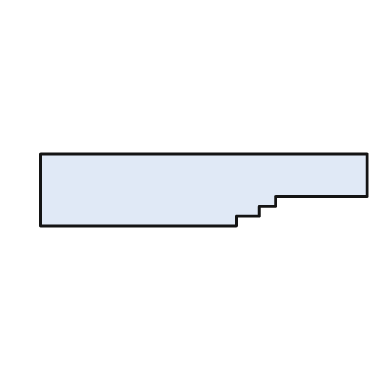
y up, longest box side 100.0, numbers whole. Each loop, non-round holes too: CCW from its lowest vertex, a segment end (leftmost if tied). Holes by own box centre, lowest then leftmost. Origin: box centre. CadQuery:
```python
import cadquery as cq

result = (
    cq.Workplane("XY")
    .moveTo(-50.0, -11.0)
    .lineTo(10.0, -11.0)
    .lineTo(10.0, -8.0)
    .lineTo(17.0, -8.0)
    .lineTo(17.0, -5.0)
    .lineTo(22.0, -5.0)
    .lineTo(22.0, -2.0)
    .lineTo(50.0, -2.0)
    .lineTo(50.0, 11.0)
    .lineTo(-50.0, 11.0)
    .close()
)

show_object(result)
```